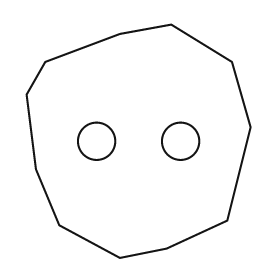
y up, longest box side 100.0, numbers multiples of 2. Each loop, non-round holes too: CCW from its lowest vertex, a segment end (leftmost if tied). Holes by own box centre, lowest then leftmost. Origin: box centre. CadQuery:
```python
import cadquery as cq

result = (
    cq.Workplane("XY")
    .moveTo(-8.0, -50.0)
    .lineTo(12.0, -46.0)
    .lineTo(38.0, -34.0)
    .lineTo(48.0, 6.0)
    .lineTo(40.0, 34.0)
    .lineTo(14.0, 50.0)
    .lineTo(-8.0, 46.0)
    .lineTo(-40.0, 34.0)
    .lineTo(-48.0, 20.0)
    .lineTo(-44.0, -12.0)
    .lineTo(-34.0, -36.0)
    .close()
    .moveTo(-18.0, 0.0)
    .circle(8.0)
    .moveTo(18.0, 0.0)
    .circle(8.0)
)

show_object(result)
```